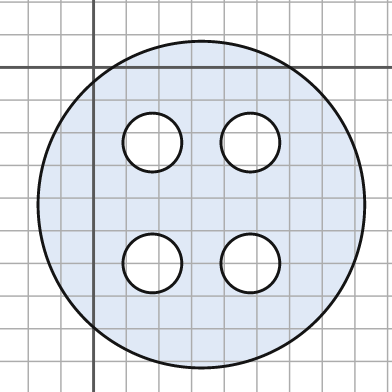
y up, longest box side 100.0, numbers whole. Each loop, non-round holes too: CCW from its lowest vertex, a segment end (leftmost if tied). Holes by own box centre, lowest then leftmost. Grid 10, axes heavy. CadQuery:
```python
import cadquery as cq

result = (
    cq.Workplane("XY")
    .moveTo(33.0, -42.0)
    .circle(50.0)
    .moveTo(18.0, -60.0)
    .circle(9.0)
    .moveTo(48.0, -60.0)
    .circle(9.0)
    .moveTo(18.0, -23.0)
    .circle(9.0)
    .moveTo(48.0, -23.0)
    .circle(9.0)
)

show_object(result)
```